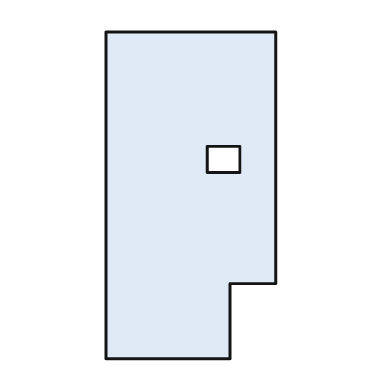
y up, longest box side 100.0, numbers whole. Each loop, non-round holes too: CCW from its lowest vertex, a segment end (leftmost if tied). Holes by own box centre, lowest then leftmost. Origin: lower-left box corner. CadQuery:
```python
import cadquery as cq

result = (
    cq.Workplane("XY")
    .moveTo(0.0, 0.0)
    .lineTo(38.0, 0.0)
    .lineTo(38.0, 23.0)
    .lineTo(52.0, 23.0)
    .lineTo(52.0, 100.0)
    .lineTo(0.0, 100.0)
    .close()
    .moveTo(31.0, 57.0)
    .lineTo(41.0, 57.0)
    .lineTo(41.0, 65.0)
    .lineTo(31.0, 65.0)
    .close()
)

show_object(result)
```